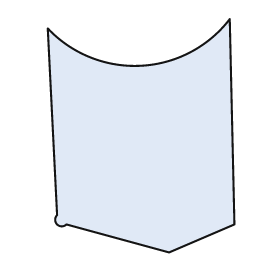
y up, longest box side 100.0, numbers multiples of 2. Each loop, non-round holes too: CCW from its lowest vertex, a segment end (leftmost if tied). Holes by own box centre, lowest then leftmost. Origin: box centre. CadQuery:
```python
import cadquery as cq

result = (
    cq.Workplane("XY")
    .moveTo(12.0, -50.0)
    .lineTo(40.0, -38.0)
    .lineTo(38.0, 50.0)
    .threePointArc((0.0, 30.0), (-40.0, 46.0))
    .lineTo(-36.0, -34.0)
    .threePointArc((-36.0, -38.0), (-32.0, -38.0))
    .close()
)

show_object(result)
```